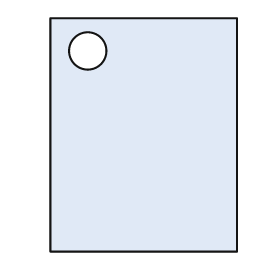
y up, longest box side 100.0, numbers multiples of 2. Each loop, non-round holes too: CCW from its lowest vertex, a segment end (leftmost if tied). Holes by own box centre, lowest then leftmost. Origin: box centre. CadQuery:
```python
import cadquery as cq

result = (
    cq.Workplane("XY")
    .moveTo(-40.0, -50.0)
    .lineTo(40.0, -50.0)
    .lineTo(40.0, 50.0)
    .lineTo(-40.0, 50.0)
    .close()
    .moveTo(-24.0, 36.0)
    .circle(8.0)
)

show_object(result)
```